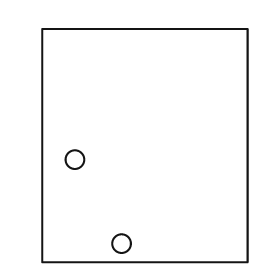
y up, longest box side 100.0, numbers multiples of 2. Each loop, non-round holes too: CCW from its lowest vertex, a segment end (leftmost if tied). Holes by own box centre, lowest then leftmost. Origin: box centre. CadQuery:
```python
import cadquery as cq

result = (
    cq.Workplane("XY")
    .moveTo(-44.0, -50.0)
    .lineTo(44.0, -50.0)
    .lineTo(44.0, 50.0)
    .lineTo(-44.0, 50.0)
    .close()
    .moveTo(-10.0, -42.0)
    .circle(4.0)
    .moveTo(-30.0, -6.0)
    .circle(4.0)
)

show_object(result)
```